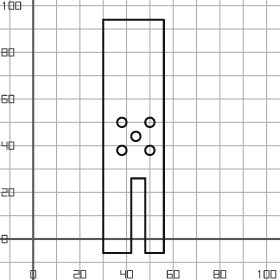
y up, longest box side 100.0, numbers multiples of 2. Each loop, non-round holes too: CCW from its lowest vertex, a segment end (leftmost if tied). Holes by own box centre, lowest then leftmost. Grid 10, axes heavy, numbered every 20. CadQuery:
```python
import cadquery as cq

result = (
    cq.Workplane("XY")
    .moveTo(30.0, -6.0)
    .lineTo(42.0, -6.0)
    .lineTo(42.0, 26.0)
    .lineTo(48.0, 26.0)
    .lineTo(48.0, -6.0)
    .lineTo(56.0, -6.0)
    .lineTo(56.0, 94.0)
    .lineTo(30.0, 94.0)
    .close()
    .moveTo(38.0, 38.0)
    .circle(2.0)
    .moveTo(50.0, 38.0)
    .circle(2.0)
    .moveTo(44.0, 44.0)
    .circle(2.0)
    .moveTo(38.0, 50.0)
    .circle(2.0)
    .moveTo(50.0, 50.0)
    .circle(2.0)
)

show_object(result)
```